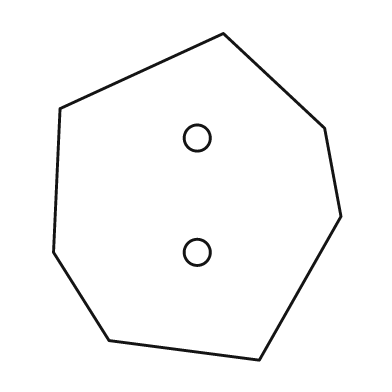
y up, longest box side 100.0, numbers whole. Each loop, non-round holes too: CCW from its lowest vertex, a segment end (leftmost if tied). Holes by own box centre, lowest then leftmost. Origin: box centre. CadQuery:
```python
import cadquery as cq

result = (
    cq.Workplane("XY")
    .moveTo(19.0, -50.0)
    .lineTo(44.0, -6.0)
    .lineTo(39.0, 21.0)
    .lineTo(8.0, 50.0)
    .lineTo(-42.0, 27.0)
    .lineTo(-44.0, -17.0)
    .lineTo(-27.0, -44.0)
    .close()
    .moveTo(0.0, -17.0)
    .circle(4.0)
    .moveTo(0.0, 18.0)
    .circle(4.0)
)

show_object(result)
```